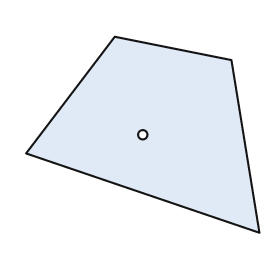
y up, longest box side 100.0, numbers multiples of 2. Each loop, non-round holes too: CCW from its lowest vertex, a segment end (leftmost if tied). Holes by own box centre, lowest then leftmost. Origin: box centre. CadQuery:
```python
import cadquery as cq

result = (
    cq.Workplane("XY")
    .moveTo(50.0, -42.0)
    .lineTo(38.0, 32.0)
    .lineTo(-12.0, 42.0)
    .lineTo(-50.0, -8.0)
    .close()
    .moveTo(0.0, 0.0)
    .circle(2.0)
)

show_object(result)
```